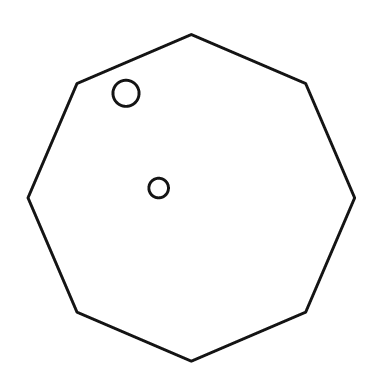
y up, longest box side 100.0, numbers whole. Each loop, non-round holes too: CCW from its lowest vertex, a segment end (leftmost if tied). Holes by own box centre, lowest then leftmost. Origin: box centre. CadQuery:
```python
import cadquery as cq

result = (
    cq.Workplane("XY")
    .moveTo(0.0, -50.0)
    .lineTo(35.0, -35.0)
    .lineTo(50.0, 0.0)
    .lineTo(35.0, 35.0)
    .lineTo(0.0, 50.0)
    .lineTo(-35.0, 35.0)
    .lineTo(-50.0, 0.0)
    .lineTo(-35.0, -35.0)
    .close()
    .moveTo(-10.0, 3.0)
    .circle(3.0)
    .moveTo(-20.0, 32.0)
    .circle(4.0)
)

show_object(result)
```